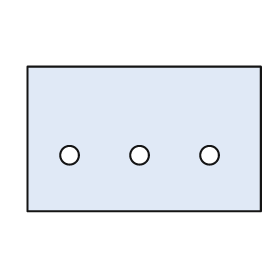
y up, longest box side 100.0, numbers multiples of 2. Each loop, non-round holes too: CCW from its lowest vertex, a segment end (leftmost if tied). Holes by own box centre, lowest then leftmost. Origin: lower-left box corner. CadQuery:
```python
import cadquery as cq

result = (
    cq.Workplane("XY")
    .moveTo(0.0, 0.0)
    .lineTo(100.0, 0.0)
    .lineTo(100.0, 62.0)
    .lineTo(0.0, 62.0)
    .close()
    .moveTo(18.0, 24.0)
    .circle(4.0)
    .moveTo(48.0, 24.0)
    .circle(4.0)
    .moveTo(78.0, 24.0)
    .circle(4.0)
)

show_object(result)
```